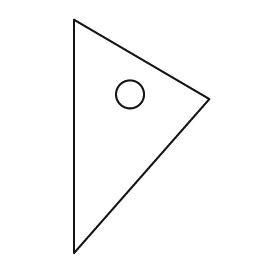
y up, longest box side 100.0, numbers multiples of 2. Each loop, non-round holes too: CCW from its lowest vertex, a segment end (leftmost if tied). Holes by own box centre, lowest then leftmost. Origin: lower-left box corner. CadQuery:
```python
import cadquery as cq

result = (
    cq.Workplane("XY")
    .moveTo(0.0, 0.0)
    .lineTo(58.0, 66.0)
    .lineTo(0.0, 100.0)
    .close()
    .moveTo(24.0, 68.0)
    .circle(6.0)
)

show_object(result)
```